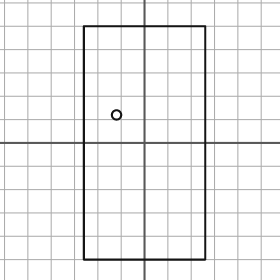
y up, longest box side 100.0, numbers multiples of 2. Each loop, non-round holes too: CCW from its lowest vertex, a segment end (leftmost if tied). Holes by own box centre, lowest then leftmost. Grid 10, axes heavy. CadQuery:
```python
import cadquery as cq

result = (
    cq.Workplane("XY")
    .moveTo(-26.0, -50.0)
    .lineTo(26.0, -50.0)
    .lineTo(26.0, 50.0)
    .lineTo(-26.0, 50.0)
    .close()
    .moveTo(-12.0, 12.0)
    .circle(2.0)
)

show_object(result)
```